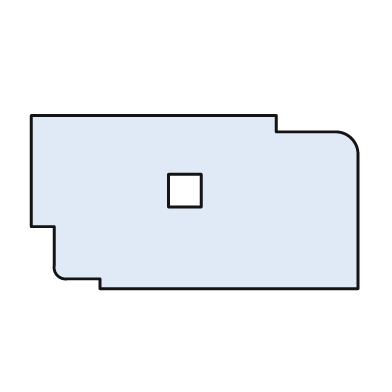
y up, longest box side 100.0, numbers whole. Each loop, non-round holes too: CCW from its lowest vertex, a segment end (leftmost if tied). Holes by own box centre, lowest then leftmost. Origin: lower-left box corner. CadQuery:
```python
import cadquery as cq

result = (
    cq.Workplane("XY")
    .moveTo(21.0, 0.0)
    .lineTo(100.0, 0.0)
    .lineTo(100.0, 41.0)
    .threePointArc((98.0, 46.0), (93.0, 48.0))
    .lineTo(75.0, 48.0)
    .lineTo(75.0, 53.0)
    .lineTo(0.0, 53.0)
    .lineTo(0.0, 19.0)
    .lineTo(7.0, 19.0)
    .lineTo(7.0, 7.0)
    .threePointArc((8.0, 4.0), (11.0, 3.0))
    .lineTo(21.0, 3.0)
    .close()
    .moveTo(42.0, 25.0)
    .lineTo(52.0, 25.0)
    .lineTo(52.0, 35.0)
    .lineTo(42.0, 35.0)
    .close()
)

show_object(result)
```